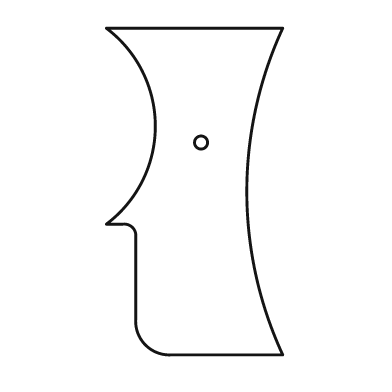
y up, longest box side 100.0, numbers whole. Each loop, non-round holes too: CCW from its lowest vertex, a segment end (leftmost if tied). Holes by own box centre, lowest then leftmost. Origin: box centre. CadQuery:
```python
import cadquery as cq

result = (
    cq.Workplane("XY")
    .moveTo(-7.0, -50.0)
    .lineTo(27.0, -50.0)
    .threePointArc((16.0, 0.0), (27.0, 50.0))
    .lineTo(-27.0, 50.0)
    .threePointArc((-12.0, 20.0), (-27.0, -10.0))
    .lineTo(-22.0, -10.0)
    .threePointArc((-19.0, -11.0), (-18.0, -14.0))
    .lineTo(-18.0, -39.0)
    .threePointArc((-15.0, -47.0), (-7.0, -50.0))
    .close()
    .moveTo(2.0, 15.0)
    .circle(2.0)
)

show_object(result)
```